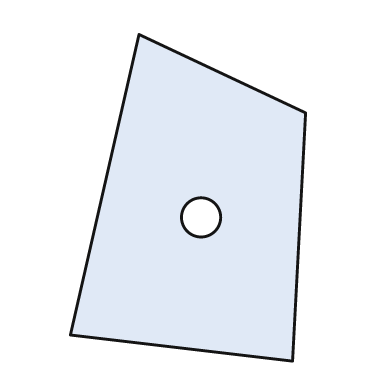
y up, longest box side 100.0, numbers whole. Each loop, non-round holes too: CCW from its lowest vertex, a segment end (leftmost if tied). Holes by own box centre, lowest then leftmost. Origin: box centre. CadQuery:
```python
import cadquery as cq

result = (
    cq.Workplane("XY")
    .moveTo(32.0, -50.0)
    .lineTo(36.0, 26.0)
    .lineTo(-15.0, 50.0)
    .lineTo(-36.0, -42.0)
    .close()
    .moveTo(4.0, -6.0)
    .circle(6.0)
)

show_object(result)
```